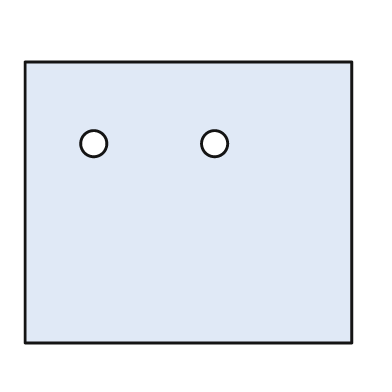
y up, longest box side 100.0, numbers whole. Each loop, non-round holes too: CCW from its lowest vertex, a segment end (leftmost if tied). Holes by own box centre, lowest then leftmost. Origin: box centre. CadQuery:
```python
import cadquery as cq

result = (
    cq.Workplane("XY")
    .moveTo(-50.0, -43.0)
    .lineTo(50.0, -43.0)
    .lineTo(50.0, 43.0)
    .lineTo(-50.0, 43.0)
    .close()
    .moveTo(-29.0, 18.0)
    .circle(4.0)
    .moveTo(8.0, 18.0)
    .circle(4.0)
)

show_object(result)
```